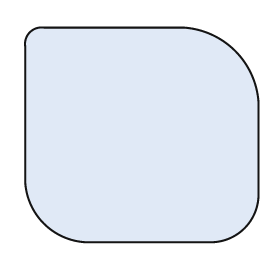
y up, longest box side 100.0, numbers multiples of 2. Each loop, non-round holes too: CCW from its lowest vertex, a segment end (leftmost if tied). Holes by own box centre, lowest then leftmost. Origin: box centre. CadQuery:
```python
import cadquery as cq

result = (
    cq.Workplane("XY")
    .moveTo(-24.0, -46.0)
    .lineTo(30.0, -46.0)
    .threePointArc((44.0, -40.0), (50.0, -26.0))
    .lineTo(50.0, 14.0)
    .threePointArc((40.0, 36.0), (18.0, 46.0))
    .lineTo(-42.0, 46.0)
    .threePointArc((-48.0, 44.0), (-50.0, 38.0))
    .lineTo(-50.0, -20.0)
    .threePointArc((-42.0, -38.0), (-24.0, -46.0))
    .close()
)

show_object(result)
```